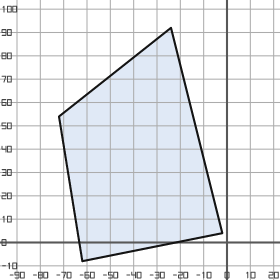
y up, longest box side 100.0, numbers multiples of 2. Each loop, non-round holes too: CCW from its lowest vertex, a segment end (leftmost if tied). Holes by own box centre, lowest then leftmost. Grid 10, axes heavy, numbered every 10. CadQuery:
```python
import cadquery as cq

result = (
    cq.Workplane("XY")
    .moveTo(-62.0, -8.0)
    .lineTo(-2.0, 4.0)
    .lineTo(-24.0, 92.0)
    .lineTo(-72.0, 54.0)
    .close()
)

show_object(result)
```